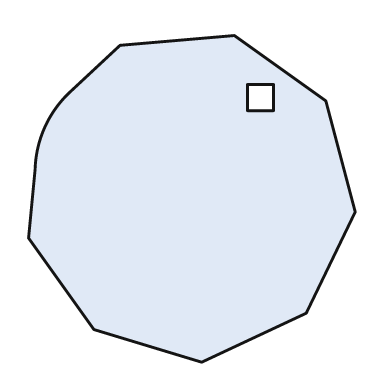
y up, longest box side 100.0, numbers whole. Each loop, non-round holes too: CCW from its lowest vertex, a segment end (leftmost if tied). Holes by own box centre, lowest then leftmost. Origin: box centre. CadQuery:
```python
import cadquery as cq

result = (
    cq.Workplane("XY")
    .moveTo(3.0, -50.0)
    .lineTo(35.0, -35.0)
    .lineTo(50.0, -4.0)
    .lineTo(41.0, 30.0)
    .lineTo(13.0, 50.0)
    .lineTo(-22.0, 47.0)
    .lineTo(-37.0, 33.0)
    .threePointArc((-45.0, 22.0), (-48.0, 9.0))
    .lineTo(-50.0, -12.0)
    .lineTo(-30.0, -40.0)
    .close()
    .moveTo(17.0, 27.0)
    .lineTo(25.0, 27.0)
    .lineTo(25.0, 35.0)
    .lineTo(17.0, 35.0)
    .close()
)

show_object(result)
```